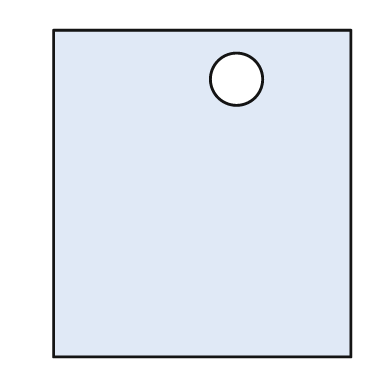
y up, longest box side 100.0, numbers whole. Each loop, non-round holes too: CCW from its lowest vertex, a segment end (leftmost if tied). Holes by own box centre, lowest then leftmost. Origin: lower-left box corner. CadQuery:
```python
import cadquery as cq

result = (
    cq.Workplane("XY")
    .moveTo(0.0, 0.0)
    .lineTo(91.0, 0.0)
    .lineTo(91.0, 100.0)
    .lineTo(0.0, 100.0)
    .close()
    .moveTo(56.0, 85.0)
    .circle(8.0)
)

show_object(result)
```